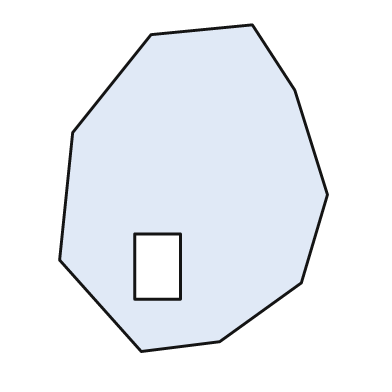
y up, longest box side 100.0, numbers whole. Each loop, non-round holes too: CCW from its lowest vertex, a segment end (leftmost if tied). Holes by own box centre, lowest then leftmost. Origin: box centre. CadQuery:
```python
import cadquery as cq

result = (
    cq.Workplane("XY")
    .moveTo(-16.0, -50.0)
    .lineTo(8.0, -47.0)
    .lineTo(33.0, -29.0)
    .lineTo(41.0, -2.0)
    .lineTo(31.0, 30.0)
    .lineTo(18.0, 50.0)
    .lineTo(-13.0, 47.0)
    .lineTo(-37.0, 17.0)
    .lineTo(-41.0, -22.0)
    .close()
    .moveTo(-18.0, -34.0)
    .lineTo(-4.0, -34.0)
    .lineTo(-4.0, -14.0)
    .lineTo(-18.0, -14.0)
    .close()
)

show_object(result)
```